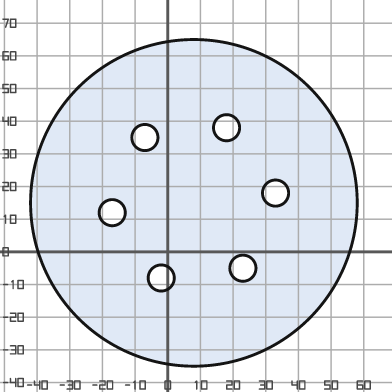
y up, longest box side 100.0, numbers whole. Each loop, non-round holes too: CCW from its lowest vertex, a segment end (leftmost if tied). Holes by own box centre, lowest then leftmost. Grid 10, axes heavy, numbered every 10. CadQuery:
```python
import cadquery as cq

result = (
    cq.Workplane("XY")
    .moveTo(8.0, 15.0)
    .circle(50.0)
    .moveTo(-2.0, -8.0)
    .circle(4.0)
    .moveTo(23.0, -5.0)
    .circle(4.0)
    .moveTo(-17.0, 12.0)
    .circle(4.0)
    .moveTo(33.0, 18.0)
    .circle(4.0)
    .moveTo(-7.0, 35.0)
    .circle(4.0)
    .moveTo(18.0, 38.0)
    .circle(4.0)
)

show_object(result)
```